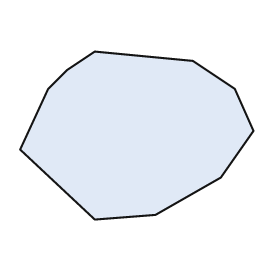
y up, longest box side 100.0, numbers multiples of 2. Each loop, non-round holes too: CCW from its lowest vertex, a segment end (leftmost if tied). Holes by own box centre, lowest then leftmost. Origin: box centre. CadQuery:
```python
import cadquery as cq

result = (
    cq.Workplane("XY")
    .moveTo(-18.0, -36.0)
    .lineTo(8.0, -34.0)
    .lineTo(36.0, -18.0)
    .lineTo(50.0, 2.0)
    .lineTo(42.0, 20.0)
    .lineTo(24.0, 32.0)
    .lineTo(-18.0, 36.0)
    .lineTo(-30.0, 28.0)
    .lineTo(-38.0, 20.0)
    .lineTo(-50.0, -6.0)
    .close()
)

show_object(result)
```